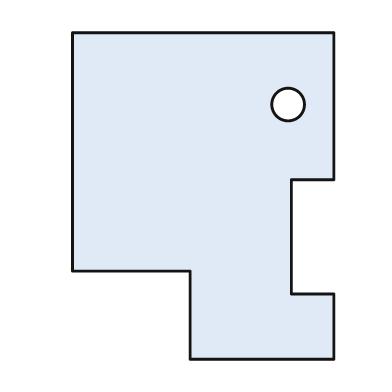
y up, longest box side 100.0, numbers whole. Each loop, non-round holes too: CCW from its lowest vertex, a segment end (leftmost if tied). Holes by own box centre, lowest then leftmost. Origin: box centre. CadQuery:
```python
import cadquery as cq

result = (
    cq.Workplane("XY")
    .moveTo(-4.0, -50.0)
    .lineTo(40.0, -50.0)
    .lineTo(40.0, -30.0)
    .lineTo(27.0, -30.0)
    .lineTo(27.0, 5.0)
    .lineTo(40.0, 5.0)
    .lineTo(40.0, 50.0)
    .lineTo(-40.0, 50.0)
    .lineTo(-40.0, -23.0)
    .lineTo(-4.0, -23.0)
    .close()
    .moveTo(26.0, 28.0)
    .circle(5.0)
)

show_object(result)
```